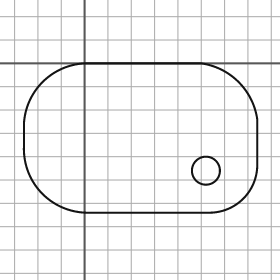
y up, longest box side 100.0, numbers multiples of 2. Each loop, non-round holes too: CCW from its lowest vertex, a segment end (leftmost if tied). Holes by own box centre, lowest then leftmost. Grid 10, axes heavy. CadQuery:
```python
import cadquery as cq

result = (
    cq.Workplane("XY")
    .moveTo(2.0, -64.0)
    .lineTo(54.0, -64.0)
    .threePointArc((68.0, -58.0), (74.0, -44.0))
    .lineTo(74.0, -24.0)
    .threePointArc((66.0, -8.0), (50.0, 0.0))
    .lineTo(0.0, 0.0)
    .threePointArc((-18.0, -8.0), (-26.0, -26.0))
    .lineTo(-26.0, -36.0)
    .threePointArc((-18.0, -56.0), (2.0, -64.0))
    .close()
    .moveTo(52.0, -46.0)
    .circle(6.0)
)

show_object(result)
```